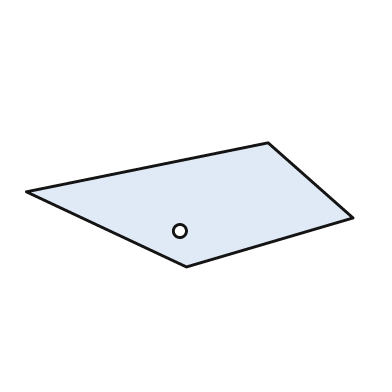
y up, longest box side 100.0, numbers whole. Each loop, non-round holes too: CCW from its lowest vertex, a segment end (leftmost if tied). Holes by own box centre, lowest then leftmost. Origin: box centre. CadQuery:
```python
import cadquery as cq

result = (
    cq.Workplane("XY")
    .moveTo(-1.0, -19.0)
    .lineTo(50.0, -4.0)
    .lineTo(24.0, 19.0)
    .lineTo(-50.0, 4.0)
    .close()
    .moveTo(-3.0, -8.0)
    .circle(2.0)
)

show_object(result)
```